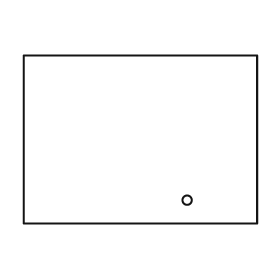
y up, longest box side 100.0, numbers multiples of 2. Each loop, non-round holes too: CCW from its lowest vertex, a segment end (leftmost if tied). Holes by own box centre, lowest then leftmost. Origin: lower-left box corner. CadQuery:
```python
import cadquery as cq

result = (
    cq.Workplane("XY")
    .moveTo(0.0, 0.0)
    .lineTo(100.0, 0.0)
    .lineTo(100.0, 72.0)
    .lineTo(0.0, 72.0)
    .close()
    .moveTo(70.0, 10.0)
    .circle(2.0)
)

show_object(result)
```